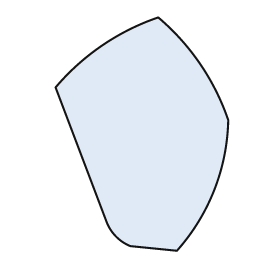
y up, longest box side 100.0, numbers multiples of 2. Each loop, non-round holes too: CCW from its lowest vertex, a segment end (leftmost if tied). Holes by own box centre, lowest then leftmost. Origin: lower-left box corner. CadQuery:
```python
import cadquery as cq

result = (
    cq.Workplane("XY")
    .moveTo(52.0, 0.0)
    .threePointArc((68.0, 26.0), (74.0, 56.0))
    .threePointArc((62.0, 80.0), (44.0, 100.0))
    .threePointArc((20.0, 88.0), (0.0, 70.0))
    .lineTo(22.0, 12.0)
    .threePointArc((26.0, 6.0), (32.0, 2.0))
    .close()
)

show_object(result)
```